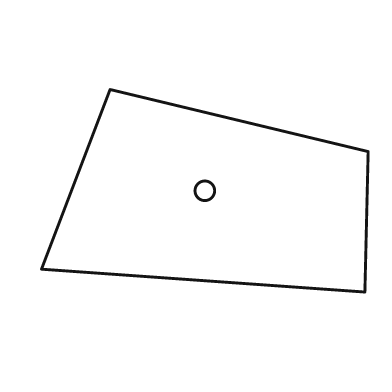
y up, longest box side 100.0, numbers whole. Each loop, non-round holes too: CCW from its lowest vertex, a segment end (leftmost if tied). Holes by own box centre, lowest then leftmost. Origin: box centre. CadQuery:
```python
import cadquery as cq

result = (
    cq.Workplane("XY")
    .moveTo(49.0, -31.0)
    .lineTo(50.0, 12.0)
    .lineTo(-29.0, 31.0)
    .lineTo(-50.0, -24.0)
    .close()
    .moveTo(0.0, 0.0)
    .circle(3.0)
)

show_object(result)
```